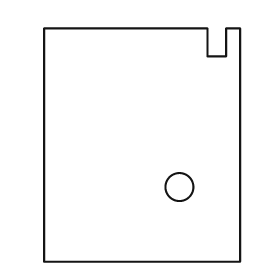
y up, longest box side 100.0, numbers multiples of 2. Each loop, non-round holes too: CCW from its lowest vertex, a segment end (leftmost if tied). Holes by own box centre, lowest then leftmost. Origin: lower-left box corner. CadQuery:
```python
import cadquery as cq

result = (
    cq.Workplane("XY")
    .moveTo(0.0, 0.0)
    .lineTo(84.0, 0.0)
    .lineTo(84.0, 100.0)
    .lineTo(78.0, 100.0)
    .lineTo(78.0, 88.0)
    .lineTo(70.0, 88.0)
    .lineTo(70.0, 100.0)
    .lineTo(0.0, 100.0)
    .close()
    .moveTo(58.0, 32.0)
    .circle(6.0)
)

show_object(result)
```